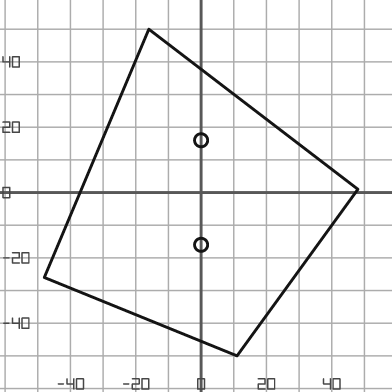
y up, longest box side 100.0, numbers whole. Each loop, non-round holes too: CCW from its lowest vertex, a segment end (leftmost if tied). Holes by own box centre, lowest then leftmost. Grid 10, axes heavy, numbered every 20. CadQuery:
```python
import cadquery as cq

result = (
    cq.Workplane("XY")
    .moveTo(11.0, -50.0)
    .lineTo(48.0, 1.0)
    .lineTo(-16.0, 50.0)
    .lineTo(-48.0, -26.0)
    .close()
    .moveTo(0.0, -16.0)
    .circle(2.0)
    .moveTo(0.0, 16.0)
    .circle(2.0)
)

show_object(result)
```